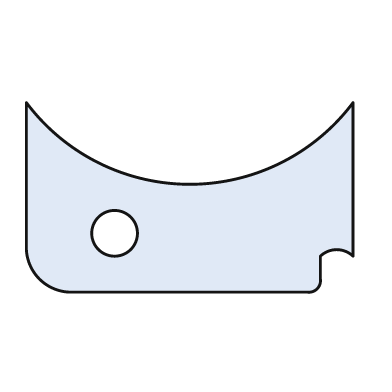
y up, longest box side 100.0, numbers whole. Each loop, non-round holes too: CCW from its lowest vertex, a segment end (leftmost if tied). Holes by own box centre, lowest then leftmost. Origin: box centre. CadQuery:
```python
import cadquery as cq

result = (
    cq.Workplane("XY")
    .moveTo(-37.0, -29.0)
    .lineTo(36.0, -29.0)
    .threePointArc((39.0, -28.0), (40.0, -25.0))
    .lineTo(40.0, -18.0)
    .threePointArc((45.0, -16.0), (50.0, -18.0))
    .lineTo(50.0, 29.0)
    .threePointArc((0.0, 4.0), (-50.0, 29.0))
    .lineTo(-50.0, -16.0)
    .threePointArc((-46.0, -25.0), (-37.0, -29.0))
    .close()
    .moveTo(-23.0, -11.0)
    .circle(7.0)
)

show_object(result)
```